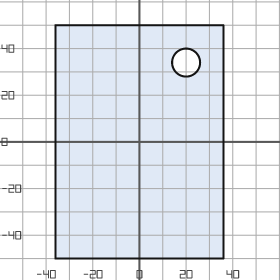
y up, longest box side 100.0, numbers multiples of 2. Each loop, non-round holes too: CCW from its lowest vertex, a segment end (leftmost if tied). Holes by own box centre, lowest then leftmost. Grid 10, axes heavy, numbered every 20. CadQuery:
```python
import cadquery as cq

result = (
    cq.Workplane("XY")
    .moveTo(-36.0, -50.0)
    .lineTo(36.0, -50.0)
    .lineTo(36.0, 50.0)
    .lineTo(-36.0, 50.0)
    .close()
    .moveTo(20.0, 34.0)
    .circle(6.0)
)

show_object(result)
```